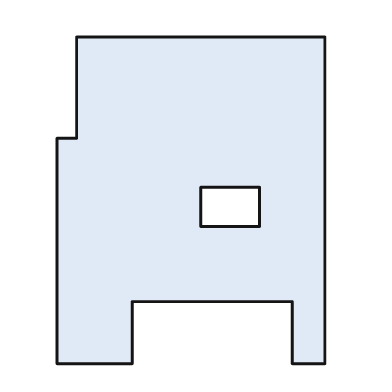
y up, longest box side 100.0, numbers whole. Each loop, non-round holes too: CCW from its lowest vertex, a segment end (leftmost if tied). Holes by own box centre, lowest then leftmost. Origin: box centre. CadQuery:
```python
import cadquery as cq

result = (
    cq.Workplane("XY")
    .moveTo(-41.0, -50.0)
    .lineTo(-18.0, -50.0)
    .lineTo(-18.0, -31.0)
    .lineTo(31.0, -31.0)
    .lineTo(31.0, -50.0)
    .lineTo(41.0, -50.0)
    .lineTo(41.0, 50.0)
    .lineTo(-35.0, 50.0)
    .lineTo(-35.0, 19.0)
    .lineTo(-41.0, 19.0)
    .close()
    .moveTo(3.0, -8.0)
    .lineTo(21.0, -8.0)
    .lineTo(21.0, 4.0)
    .lineTo(3.0, 4.0)
    .close()
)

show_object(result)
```